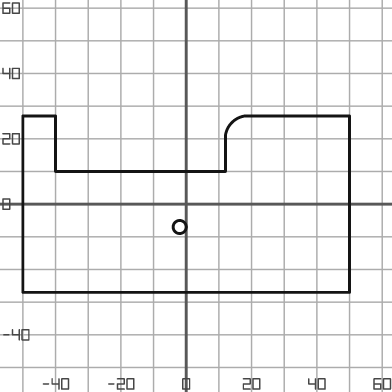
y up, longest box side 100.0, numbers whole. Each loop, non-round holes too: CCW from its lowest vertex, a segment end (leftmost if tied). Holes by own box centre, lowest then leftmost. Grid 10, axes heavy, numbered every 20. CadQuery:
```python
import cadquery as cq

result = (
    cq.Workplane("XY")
    .moveTo(-50.0, -27.0)
    .lineTo(50.0, -27.0)
    .lineTo(50.0, 27.0)
    .lineTo(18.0, 27.0)
    .threePointArc((14.0, 25.0), (12.0, 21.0))
    .lineTo(12.0, 10.0)
    .lineTo(-40.0, 10.0)
    .lineTo(-40.0, 27.0)
    .lineTo(-50.0, 27.0)
    .close()
    .moveTo(-2.0, -7.0)
    .circle(2.0)
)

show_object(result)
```